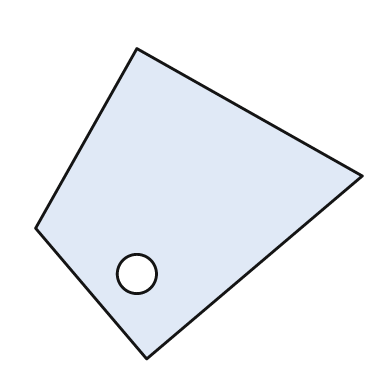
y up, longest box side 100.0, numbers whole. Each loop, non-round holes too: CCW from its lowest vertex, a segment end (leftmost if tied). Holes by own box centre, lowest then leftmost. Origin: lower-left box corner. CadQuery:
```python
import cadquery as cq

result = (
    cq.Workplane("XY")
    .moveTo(34.0, 0.0)
    .lineTo(100.0, 56.0)
    .lineTo(31.0, 95.0)
    .lineTo(0.0, 40.0)
    .close()
    .moveTo(31.0, 26.0)
    .circle(6.0)
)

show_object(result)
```